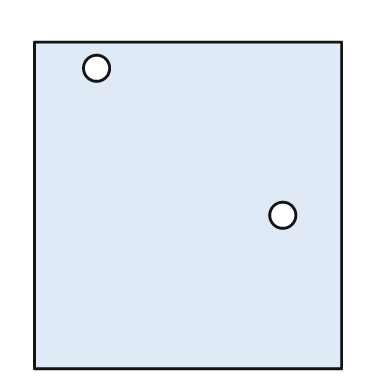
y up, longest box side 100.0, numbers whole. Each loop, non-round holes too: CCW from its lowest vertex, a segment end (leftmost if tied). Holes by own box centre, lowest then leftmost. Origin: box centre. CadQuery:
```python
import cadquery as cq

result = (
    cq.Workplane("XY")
    .moveTo(-47.0, -50.0)
    .lineTo(47.0, -50.0)
    .lineTo(47.0, 50.0)
    .lineTo(-47.0, 50.0)
    .close()
    .moveTo(29.0, -3.0)
    .circle(4.0)
    .moveTo(-28.0, 42.0)
    .circle(4.0)
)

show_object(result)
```